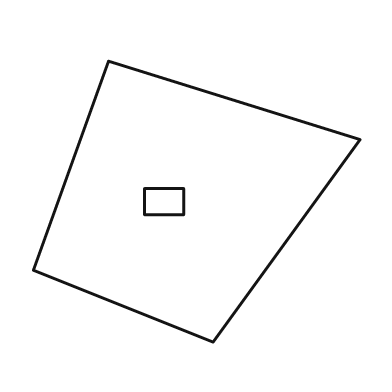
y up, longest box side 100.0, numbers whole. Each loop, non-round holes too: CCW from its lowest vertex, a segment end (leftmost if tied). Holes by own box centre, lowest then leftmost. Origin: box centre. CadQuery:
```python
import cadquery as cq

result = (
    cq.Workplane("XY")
    .moveTo(5.0, -43.0)
    .lineTo(50.0, 19.0)
    .lineTo(-27.0, 43.0)
    .lineTo(-50.0, -21.0)
    .close()
    .moveTo(-16.0, -4.0)
    .lineTo(-4.0, -4.0)
    .lineTo(-4.0, 4.0)
    .lineTo(-16.0, 4.0)
    .close()
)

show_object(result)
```